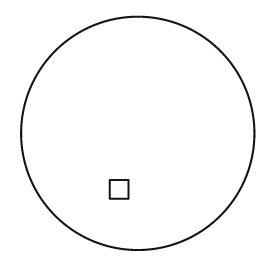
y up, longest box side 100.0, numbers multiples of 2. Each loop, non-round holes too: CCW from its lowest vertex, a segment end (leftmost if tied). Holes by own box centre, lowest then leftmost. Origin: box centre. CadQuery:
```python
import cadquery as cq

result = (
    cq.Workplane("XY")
    .moveTo(0.0, 0.0)
    .circle(50.0)
    .moveTo(-12.0, -28.0)
    .lineTo(-4.0, -28.0)
    .lineTo(-4.0, -20.0)
    .lineTo(-12.0, -20.0)
    .close()
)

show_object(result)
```